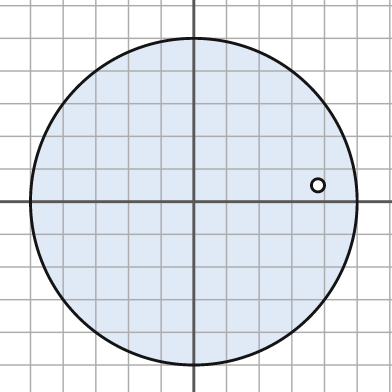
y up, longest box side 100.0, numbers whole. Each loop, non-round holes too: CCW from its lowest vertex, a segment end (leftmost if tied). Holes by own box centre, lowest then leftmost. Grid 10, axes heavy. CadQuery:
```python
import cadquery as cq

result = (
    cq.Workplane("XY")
    .moveTo(0.0, 0.0)
    .circle(50.0)
    .moveTo(38.0, 5.0)
    .circle(2.0)
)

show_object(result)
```